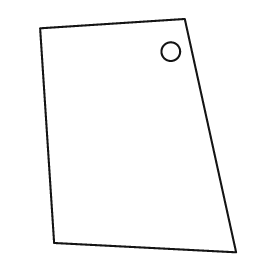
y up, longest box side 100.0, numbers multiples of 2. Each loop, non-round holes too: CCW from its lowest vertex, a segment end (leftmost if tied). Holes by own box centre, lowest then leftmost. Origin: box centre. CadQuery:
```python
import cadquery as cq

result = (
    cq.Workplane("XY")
    .moveTo(42.0, -50.0)
    .lineTo(20.0, 50.0)
    .lineTo(-42.0, 46.0)
    .lineTo(-36.0, -46.0)
    .close()
    .moveTo(14.0, 36.0)
    .circle(4.0)
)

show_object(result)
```